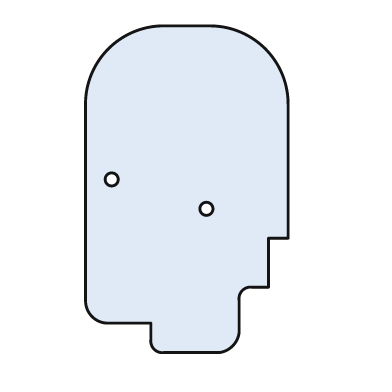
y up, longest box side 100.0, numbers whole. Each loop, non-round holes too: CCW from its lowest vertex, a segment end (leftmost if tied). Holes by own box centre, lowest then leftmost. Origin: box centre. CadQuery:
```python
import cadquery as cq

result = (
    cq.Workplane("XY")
    .moveTo(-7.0, -50.0)
    .lineTo(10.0, -50.0)
    .threePointArc((14.0, -48.0), (16.0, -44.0))
    .lineTo(16.0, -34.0)
    .threePointArc((17.0, -31.0), (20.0, -30.0))
    .lineTo(25.0, -30.0)
    .lineTo(25.0, -15.0)
    .lineTo(31.0, -15.0)
    .lineTo(31.0, 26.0)
    .threePointArc((24.0, 43.0), (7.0, 50.0))
    .lineTo(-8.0, 50.0)
    .threePointArc((-24.0, 43.0), (-31.0, 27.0))
    .lineTo(-31.0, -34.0)
    .threePointArc((-29.0, -39.0), (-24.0, -41.0))
    .lineTo(-11.0, -41.0)
    .lineTo(-11.0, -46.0)
    .threePointArc((-10.0, -49.0), (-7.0, -50.0))
    .close()
    .moveTo(6.0, -6.0)
    .circle(2.0)
    .moveTo(-23.0, 3.0)
    .circle(2.0)
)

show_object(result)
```